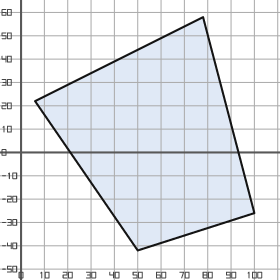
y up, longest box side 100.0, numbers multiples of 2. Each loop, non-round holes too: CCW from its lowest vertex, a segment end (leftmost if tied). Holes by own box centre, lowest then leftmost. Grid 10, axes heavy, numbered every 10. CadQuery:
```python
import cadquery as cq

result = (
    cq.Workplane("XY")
    .moveTo(50.0, -42.0)
    .lineTo(100.0, -26.0)
    .lineTo(78.0, 58.0)
    .lineTo(6.0, 22.0)
    .close()
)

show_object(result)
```